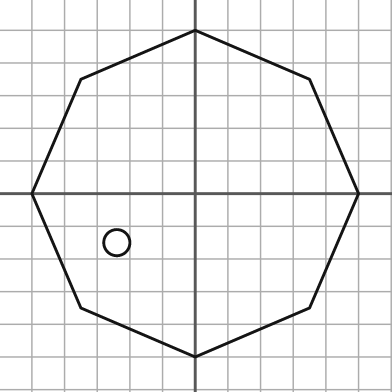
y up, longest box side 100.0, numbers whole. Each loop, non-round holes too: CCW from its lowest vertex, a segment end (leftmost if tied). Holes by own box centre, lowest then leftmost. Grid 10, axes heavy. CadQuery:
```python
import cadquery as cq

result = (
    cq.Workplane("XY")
    .moveTo(0.0, -50.0)
    .lineTo(35.0, -35.0)
    .lineTo(50.0, 0.0)
    .lineTo(35.0, 35.0)
    .lineTo(0.0, 50.0)
    .lineTo(-35.0, 35.0)
    .lineTo(-50.0, 0.0)
    .lineTo(-35.0, -35.0)
    .close()
    .moveTo(-24.0, -15.0)
    .circle(4.0)
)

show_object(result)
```